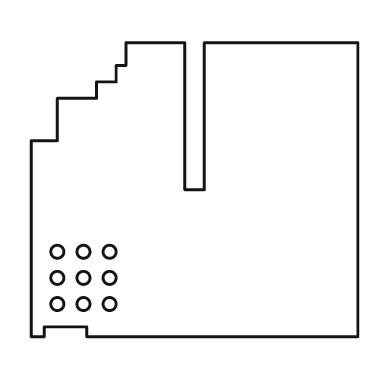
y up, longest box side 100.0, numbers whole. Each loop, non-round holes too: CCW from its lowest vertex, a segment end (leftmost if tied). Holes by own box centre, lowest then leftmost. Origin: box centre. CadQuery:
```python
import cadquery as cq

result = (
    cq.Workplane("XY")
    .moveTo(-50.0, -45.0)
    .lineTo(-46.0, -45.0)
    .lineTo(-46.0, -42.0)
    .lineTo(-33.0, -42.0)
    .lineTo(-33.0, -45.0)
    .lineTo(50.0, -45.0)
    .lineTo(50.0, 45.0)
    .lineTo(3.0, 45.0)
    .lineTo(3.0, 0.0)
    .lineTo(-3.0, 0.0)
    .lineTo(-3.0, 45.0)
    .lineTo(-21.0, 45.0)
    .lineTo(-21.0, 38.0)
    .lineTo(-24.0, 38.0)
    .lineTo(-24.0, 33.0)
    .lineTo(-30.0, 33.0)
    .lineTo(-30.0, 28.0)
    .lineTo(-42.0, 28.0)
    .lineTo(-42.0, 15.0)
    .lineTo(-50.0, 15.0)
    .close()
    .moveTo(-42.0, -35.0)
    .circle(2.0)
    .moveTo(-34.0, -35.0)
    .circle(2.0)
    .moveTo(-26.0, -35.0)
    .circle(2.0)
    .moveTo(-42.0, -27.0)
    .circle(2.0)
    .moveTo(-34.0, -27.0)
    .circle(2.0)
    .moveTo(-26.0, -27.0)
    .circle(2.0)
    .moveTo(-42.0, -19.0)
    .circle(2.0)
    .moveTo(-34.0, -19.0)
    .circle(2.0)
    .moveTo(-26.0, -19.0)
    .circle(2.0)
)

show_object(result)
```